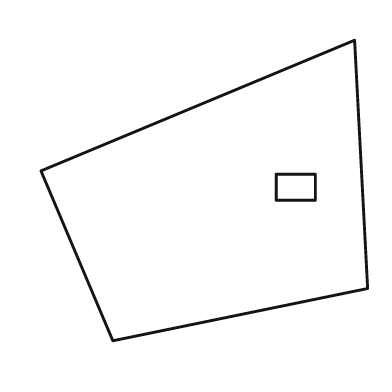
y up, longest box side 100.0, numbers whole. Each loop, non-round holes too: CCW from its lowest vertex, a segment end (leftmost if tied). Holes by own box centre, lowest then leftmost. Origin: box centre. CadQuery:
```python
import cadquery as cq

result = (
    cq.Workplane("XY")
    .moveTo(-28.0, -46.0)
    .lineTo(50.0, -30.0)
    .lineTo(46.0, 46.0)
    .lineTo(-50.0, 6.0)
    .close()
    .moveTo(22.0, -3.0)
    .lineTo(34.0, -3.0)
    .lineTo(34.0, 5.0)
    .lineTo(22.0, 5.0)
    .close()
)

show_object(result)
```